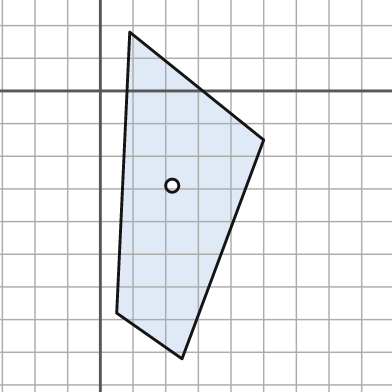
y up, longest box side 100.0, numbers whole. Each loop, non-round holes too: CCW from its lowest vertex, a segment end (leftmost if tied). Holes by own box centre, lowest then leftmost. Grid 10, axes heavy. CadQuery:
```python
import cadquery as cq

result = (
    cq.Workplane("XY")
    .moveTo(25.0, -82.0)
    .lineTo(50.0, -15.0)
    .lineTo(9.0, 18.0)
    .lineTo(5.0, -68.0)
    .close()
    .moveTo(22.0, -29.0)
    .circle(2.0)
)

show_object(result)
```